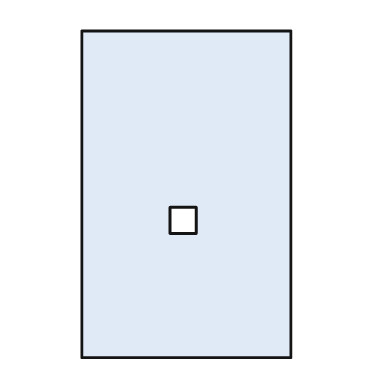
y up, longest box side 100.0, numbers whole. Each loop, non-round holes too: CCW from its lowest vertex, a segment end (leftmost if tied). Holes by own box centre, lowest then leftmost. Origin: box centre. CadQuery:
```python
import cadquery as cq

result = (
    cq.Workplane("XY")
    .moveTo(-32.0, -50.0)
    .lineTo(32.0, -50.0)
    .lineTo(32.0, 50.0)
    .lineTo(-32.0, 50.0)
    .close()
    .moveTo(-5.0, -12.0)
    .lineTo(3.0, -12.0)
    .lineTo(3.0, -4.0)
    .lineTo(-5.0, -4.0)
    .close()
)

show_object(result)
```